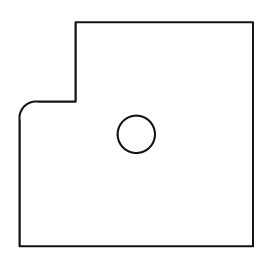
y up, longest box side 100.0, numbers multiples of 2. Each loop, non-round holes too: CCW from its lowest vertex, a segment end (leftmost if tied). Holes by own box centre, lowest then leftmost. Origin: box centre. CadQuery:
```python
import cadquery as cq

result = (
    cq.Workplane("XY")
    .moveTo(-50.0, -48.0)
    .lineTo(50.0, -48.0)
    .lineTo(50.0, 48.0)
    .lineTo(-26.0, 48.0)
    .lineTo(-26.0, 14.0)
    .lineTo(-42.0, 14.0)
    .threePointArc((-48.0, 12.0), (-50.0, 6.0))
    .close()
    .moveTo(0.0, 0.0)
    .circle(8.0)
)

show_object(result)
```